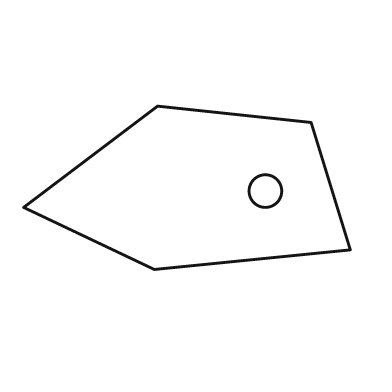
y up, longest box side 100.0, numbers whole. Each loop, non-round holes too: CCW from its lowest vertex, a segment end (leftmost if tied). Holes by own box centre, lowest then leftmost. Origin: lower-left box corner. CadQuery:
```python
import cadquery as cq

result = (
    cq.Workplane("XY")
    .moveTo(40.0, 0.0)
    .lineTo(100.0, 6.0)
    .lineTo(88.0, 45.0)
    .lineTo(41.0, 50.0)
    .lineTo(0.0, 19.0)
    .close()
    .moveTo(74.0, 24.0)
    .circle(5.0)
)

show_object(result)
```